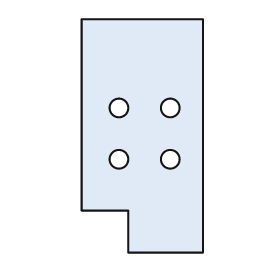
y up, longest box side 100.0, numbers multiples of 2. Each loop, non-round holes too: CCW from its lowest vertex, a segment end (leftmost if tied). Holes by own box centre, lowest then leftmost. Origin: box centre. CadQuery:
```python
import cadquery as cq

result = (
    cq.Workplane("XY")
    .moveTo(-6.0, -50.0)
    .lineTo(26.0, -50.0)
    .lineTo(26.0, 50.0)
    .lineTo(-26.0, 50.0)
    .lineTo(-26.0, -32.0)
    .lineTo(-6.0, -32.0)
    .close()
    .moveTo(-10.0, -10.0)
    .circle(4.0)
    .moveTo(12.0, -10.0)
    .circle(4.0)
    .moveTo(-10.0, 12.0)
    .circle(4.0)
    .moveTo(12.0, 12.0)
    .circle(4.0)
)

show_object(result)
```